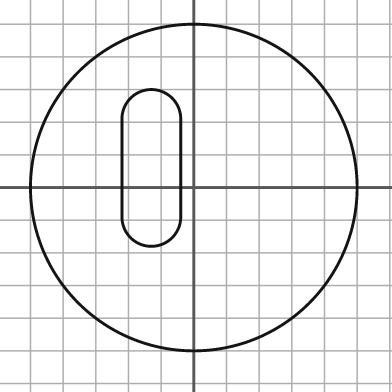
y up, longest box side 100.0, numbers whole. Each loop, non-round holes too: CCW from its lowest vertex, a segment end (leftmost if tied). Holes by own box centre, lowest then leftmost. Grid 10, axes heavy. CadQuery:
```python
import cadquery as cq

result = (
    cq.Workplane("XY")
    .moveTo(0.0, 0.0)
    .circle(50.0)
    .moveTo(-22.0, -9.0)
    .threePointArc((-13.0, -18.0), (-4.0, -9.0))
    .lineTo(-4.0, 21.0)
    .threePointArc((-13.0, 30.0), (-22.0, 21.0))
    .close()
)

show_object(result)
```